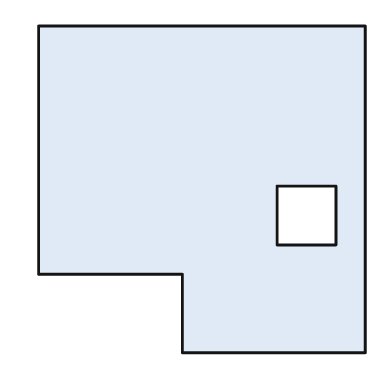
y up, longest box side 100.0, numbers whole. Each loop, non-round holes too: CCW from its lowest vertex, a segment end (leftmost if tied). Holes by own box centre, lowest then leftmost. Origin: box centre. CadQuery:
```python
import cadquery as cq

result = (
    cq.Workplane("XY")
    .moveTo(-6.0, -50.0)
    .lineTo(50.0, -50.0)
    .lineTo(50.0, 50.0)
    .lineTo(-50.0, 50.0)
    .lineTo(-50.0, -26.0)
    .lineTo(-6.0, -26.0)
    .close()
    .moveTo(23.0, -17.0)
    .lineTo(41.0, -17.0)
    .lineTo(41.0, 1.0)
    .lineTo(23.0, 1.0)
    .close()
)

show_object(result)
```